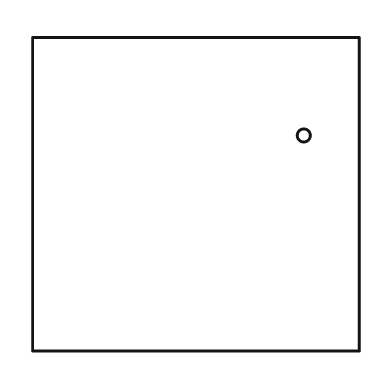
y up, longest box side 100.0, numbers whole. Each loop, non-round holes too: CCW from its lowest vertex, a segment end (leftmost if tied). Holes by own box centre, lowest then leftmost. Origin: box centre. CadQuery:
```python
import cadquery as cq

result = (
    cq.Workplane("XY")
    .moveTo(-50.0, -48.0)
    .lineTo(50.0, -48.0)
    .lineTo(50.0, 48.0)
    .lineTo(-50.0, 48.0)
    .close()
    .moveTo(33.0, 18.0)
    .circle(2.0)
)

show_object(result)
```